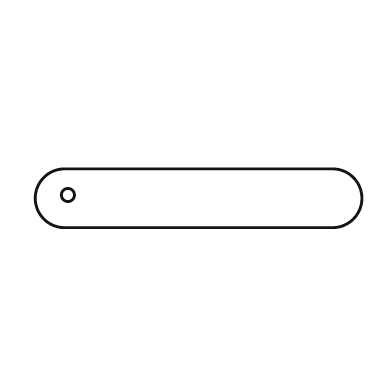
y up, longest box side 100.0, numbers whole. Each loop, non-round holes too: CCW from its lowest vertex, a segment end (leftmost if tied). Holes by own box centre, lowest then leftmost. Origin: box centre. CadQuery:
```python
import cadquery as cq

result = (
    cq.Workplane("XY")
    .moveTo(-41.0, -9.0)
    .lineTo(41.0, -9.0)
    .threePointArc((50.0, 0.0), (41.0, 9.0))
    .lineTo(-41.0, 9.0)
    .threePointArc((-50.0, 0.0), (-41.0, -9.0))
    .close()
    .moveTo(-40.0, 1.0)
    .circle(2.0)
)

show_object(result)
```